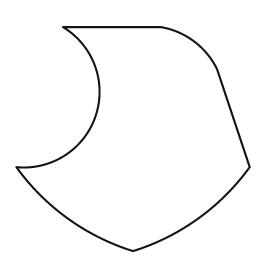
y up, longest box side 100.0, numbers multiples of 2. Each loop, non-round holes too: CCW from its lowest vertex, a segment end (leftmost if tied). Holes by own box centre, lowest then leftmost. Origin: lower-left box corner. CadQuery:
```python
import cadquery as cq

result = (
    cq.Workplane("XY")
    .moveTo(50.0, 0.0)
    .threePointArc((78.0, 14.0), (100.0, 36.0))
    .lineTo(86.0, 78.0)
    .threePointArc((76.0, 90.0), (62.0, 96.0))
    .lineTo(20.0, 96.0)
    .threePointArc((34.0, 58.0), (0.0, 36.0))
    .threePointArc((22.0, 14.0), (50.0, 0.0))
    .close()
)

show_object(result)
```